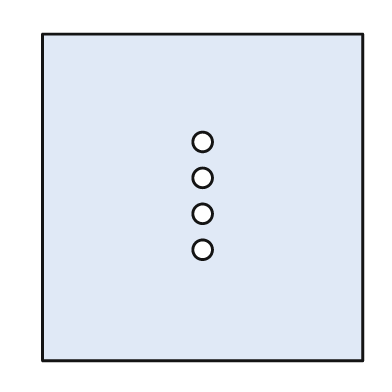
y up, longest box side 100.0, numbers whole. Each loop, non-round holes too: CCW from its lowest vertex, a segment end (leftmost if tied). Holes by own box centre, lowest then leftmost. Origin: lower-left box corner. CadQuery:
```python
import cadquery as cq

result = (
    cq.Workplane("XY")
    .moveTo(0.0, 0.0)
    .lineTo(98.0, 0.0)
    .lineTo(98.0, 100.0)
    .lineTo(0.0, 100.0)
    .close()
    .moveTo(49.0, 34.0)
    .circle(3.0)
    .moveTo(49.0, 45.0)
    .circle(3.0)
    .moveTo(49.0, 56.0)
    .circle(3.0)
    .moveTo(49.0, 67.0)
    .circle(3.0)
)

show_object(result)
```